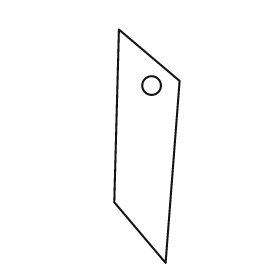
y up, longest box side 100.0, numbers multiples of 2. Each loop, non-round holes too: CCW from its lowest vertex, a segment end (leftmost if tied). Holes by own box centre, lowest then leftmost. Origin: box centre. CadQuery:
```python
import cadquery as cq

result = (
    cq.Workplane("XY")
    .moveTo(8.0, -50.0)
    .lineTo(14.0, 28.0)
    .lineTo(-12.0, 50.0)
    .lineTo(-14.0, -24.0)
    .close()
    .moveTo(2.0, 26.0)
    .circle(4.0)
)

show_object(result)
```